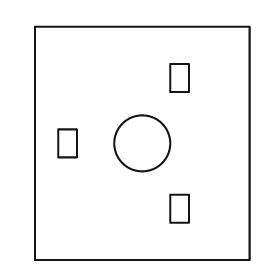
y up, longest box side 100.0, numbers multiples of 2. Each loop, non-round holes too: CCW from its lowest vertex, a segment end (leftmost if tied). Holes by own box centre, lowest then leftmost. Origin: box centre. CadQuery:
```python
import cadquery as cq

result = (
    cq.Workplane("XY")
    .moveTo(-46.0, -50.0)
    .lineTo(46.0, -50.0)
    .lineTo(46.0, 50.0)
    .lineTo(-46.0, 50.0)
    .close()
    .moveTo(12.0, -34.0)
    .lineTo(20.0, -34.0)
    .lineTo(20.0, -22.0)
    .lineTo(12.0, -22.0)
    .close()
    .moveTo(-36.0, -6.0)
    .lineTo(-28.0, -6.0)
    .lineTo(-28.0, 6.0)
    .lineTo(-36.0, 6.0)
    .close()
    .moveTo(0.0, 0.0)
    .circle(12.0)
    .moveTo(12.0, 22.0)
    .lineTo(20.0, 22.0)
    .lineTo(20.0, 34.0)
    .lineTo(12.0, 34.0)
    .close()
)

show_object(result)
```